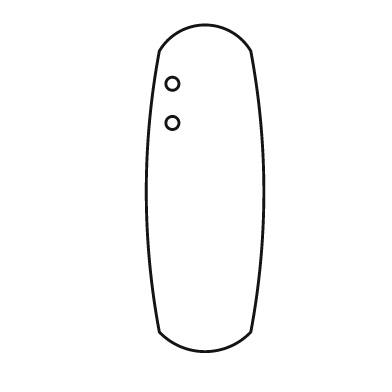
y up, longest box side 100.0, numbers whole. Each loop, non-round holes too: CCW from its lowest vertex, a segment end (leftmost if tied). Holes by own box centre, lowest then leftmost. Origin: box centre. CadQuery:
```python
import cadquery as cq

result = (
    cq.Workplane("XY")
    .moveTo(-14.0, -44.0)
    .threePointArc((0.0, -50.0), (14.0, -44.0))
    .threePointArc((18.0, -1.0), (14.0, 42.0))
    .threePointArc((0.0, 50.0), (-14.0, 42.0))
    .threePointArc((-18.0, -1.0), (-14.0, -44.0))
    .close()
    .moveTo(-10.0, 20.0)
    .circle(2.0)
    .moveTo(-10.0, 32.0)
    .circle(2.0)
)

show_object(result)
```